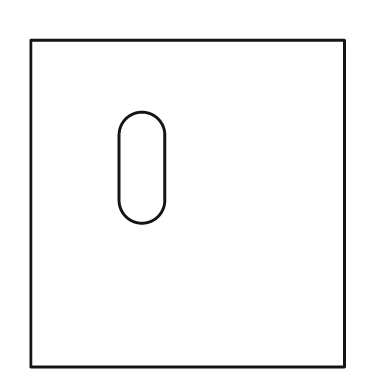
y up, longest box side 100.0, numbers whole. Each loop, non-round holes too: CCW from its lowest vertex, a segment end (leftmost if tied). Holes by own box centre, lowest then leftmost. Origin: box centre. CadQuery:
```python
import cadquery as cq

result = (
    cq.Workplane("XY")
    .moveTo(-48.0, -50.0)
    .lineTo(48.0, -50.0)
    .lineTo(48.0, 50.0)
    .lineTo(-48.0, 50.0)
    .close()
    .moveTo(-21.0, 1.0)
    .threePointArc((-14.0, -6.0), (-7.0, 1.0))
    .lineTo(-7.0, 21.0)
    .threePointArc((-14.0, 28.0), (-21.0, 21.0))
    .close()
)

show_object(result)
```